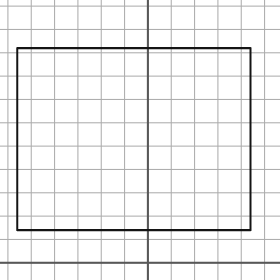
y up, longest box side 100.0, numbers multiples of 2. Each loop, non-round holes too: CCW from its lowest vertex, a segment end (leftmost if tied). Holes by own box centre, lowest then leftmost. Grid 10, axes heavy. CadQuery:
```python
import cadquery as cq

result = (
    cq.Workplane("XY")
    .moveTo(-56.0, 14.0)
    .lineTo(44.0, 14.0)
    .lineTo(44.0, 92.0)
    .lineTo(-56.0, 92.0)
    .close()
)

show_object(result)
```